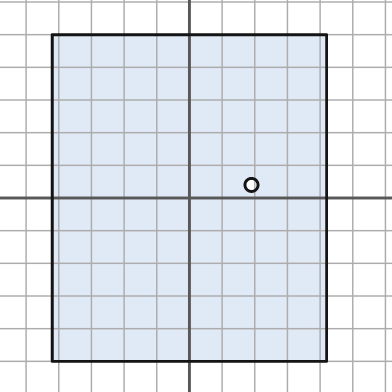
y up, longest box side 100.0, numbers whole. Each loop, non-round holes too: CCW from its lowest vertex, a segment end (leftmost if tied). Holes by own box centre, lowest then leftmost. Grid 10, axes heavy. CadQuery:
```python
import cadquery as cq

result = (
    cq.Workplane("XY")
    .moveTo(-42.0, -50.0)
    .lineTo(42.0, -50.0)
    .lineTo(42.0, 50.0)
    .lineTo(-42.0, 50.0)
    .close()
    .moveTo(19.0, 4.0)
    .circle(2.0)
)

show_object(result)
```